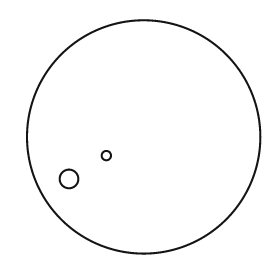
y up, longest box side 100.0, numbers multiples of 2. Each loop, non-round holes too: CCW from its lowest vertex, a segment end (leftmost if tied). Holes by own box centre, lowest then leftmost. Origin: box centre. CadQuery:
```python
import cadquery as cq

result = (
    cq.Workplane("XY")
    .moveTo(0.0, 0.0)
    .circle(50.0)
    .moveTo(-32.0, -18.0)
    .circle(4.0)
    .moveTo(-16.0, -8.0)
    .circle(2.0)
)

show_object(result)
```